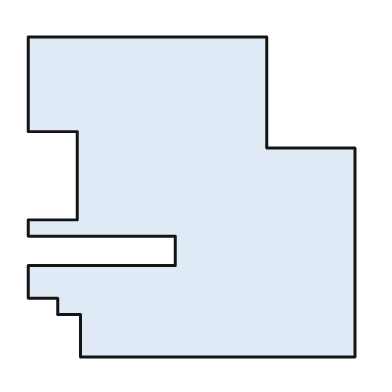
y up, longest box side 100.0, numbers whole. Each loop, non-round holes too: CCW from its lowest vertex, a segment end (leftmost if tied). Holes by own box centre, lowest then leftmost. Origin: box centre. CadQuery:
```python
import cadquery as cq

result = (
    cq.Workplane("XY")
    .moveTo(-34.0, -49.0)
    .lineTo(50.0, -49.0)
    .lineTo(50.0, 15.0)
    .lineTo(23.0, 15.0)
    .lineTo(23.0, 49.0)
    .lineTo(-50.0, 49.0)
    .lineTo(-50.0, 20.0)
    .lineTo(-35.0, 20.0)
    .lineTo(-35.0, -7.0)
    .lineTo(-50.0, -7.0)
    .lineTo(-50.0, -12.0)
    .lineTo(-5.0, -12.0)
    .lineTo(-5.0, -21.0)
    .lineTo(-50.0, -21.0)
    .lineTo(-50.0, -31.0)
    .lineTo(-41.0, -31.0)
    .lineTo(-41.0, -36.0)
    .lineTo(-34.0, -36.0)
    .close()
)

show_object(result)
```